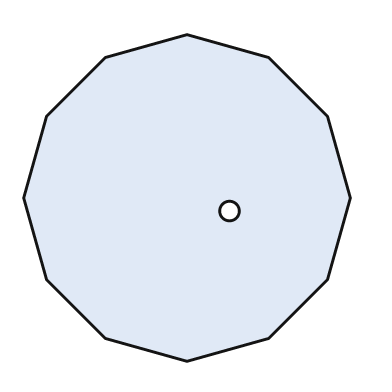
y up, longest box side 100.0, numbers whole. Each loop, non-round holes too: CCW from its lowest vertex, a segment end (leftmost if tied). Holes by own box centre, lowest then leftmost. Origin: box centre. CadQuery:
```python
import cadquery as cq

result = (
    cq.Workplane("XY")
    .moveTo(0.0, -50.0)
    .lineTo(25.0, -43.0)
    .lineTo(43.0, -25.0)
    .lineTo(50.0, 0.0)
    .lineTo(43.0, 25.0)
    .lineTo(25.0, 43.0)
    .lineTo(0.0, 50.0)
    .lineTo(-25.0, 43.0)
    .lineTo(-43.0, 25.0)
    .lineTo(-50.0, 0.0)
    .lineTo(-43.0, -25.0)
    .lineTo(-25.0, -43.0)
    .close()
    .moveTo(13.0, -4.0)
    .circle(3.0)
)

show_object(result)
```